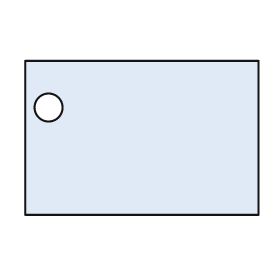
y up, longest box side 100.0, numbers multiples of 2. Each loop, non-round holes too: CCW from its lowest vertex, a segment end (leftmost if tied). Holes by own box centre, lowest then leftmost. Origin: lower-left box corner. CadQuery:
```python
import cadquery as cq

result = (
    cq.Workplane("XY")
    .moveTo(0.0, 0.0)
    .lineTo(100.0, 0.0)
    .lineTo(100.0, 66.0)
    .lineTo(0.0, 66.0)
    .close()
    .moveTo(10.0, 46.0)
    .circle(6.0)
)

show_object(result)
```